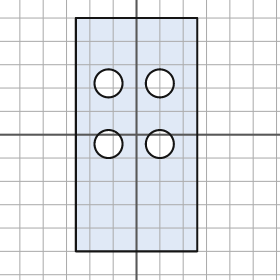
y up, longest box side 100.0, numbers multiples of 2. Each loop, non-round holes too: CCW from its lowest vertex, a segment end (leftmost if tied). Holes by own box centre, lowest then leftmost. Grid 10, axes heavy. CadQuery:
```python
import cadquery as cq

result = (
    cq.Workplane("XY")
    .moveTo(-26.0, -50.0)
    .lineTo(26.0, -50.0)
    .lineTo(26.0, 50.0)
    .lineTo(-26.0, 50.0)
    .close()
    .moveTo(-12.0, -4.0)
    .circle(6.0)
    .moveTo(10.0, -4.0)
    .circle(6.0)
    .moveTo(-12.0, 22.0)
    .circle(6.0)
    .moveTo(10.0, 22.0)
    .circle(6.0)
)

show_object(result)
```